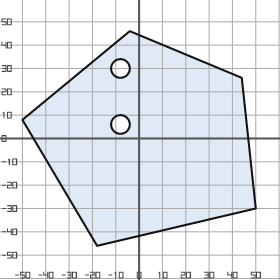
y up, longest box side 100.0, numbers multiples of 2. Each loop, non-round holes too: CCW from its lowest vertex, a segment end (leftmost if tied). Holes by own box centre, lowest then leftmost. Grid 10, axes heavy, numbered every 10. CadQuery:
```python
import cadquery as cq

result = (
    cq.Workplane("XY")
    .moveTo(-18.0, -46.0)
    .lineTo(50.0, -30.0)
    .lineTo(44.0, 26.0)
    .lineTo(-4.0, 46.0)
    .lineTo(-50.0, 8.0)
    .close()
    .moveTo(-8.0, 6.0)
    .circle(4.0)
    .moveTo(-8.0, 30.0)
    .circle(4.0)
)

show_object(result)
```